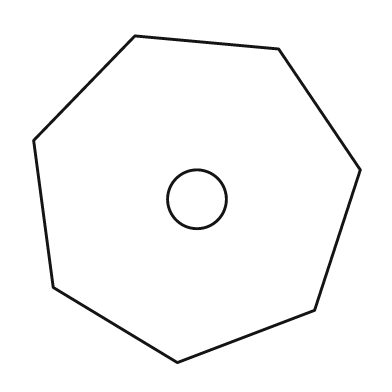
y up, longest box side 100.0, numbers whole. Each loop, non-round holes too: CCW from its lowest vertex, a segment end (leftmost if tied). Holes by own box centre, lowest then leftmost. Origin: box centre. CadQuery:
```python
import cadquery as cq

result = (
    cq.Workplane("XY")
    .moveTo(-6.0, -50.0)
    .lineTo(36.0, -34.0)
    .lineTo(50.0, 9.0)
    .lineTo(25.0, 46.0)
    .lineTo(-19.0, 50.0)
    .lineTo(-50.0, 18.0)
    .lineTo(-44.0, -27.0)
    .close()
    .moveTo(0.0, 0.0)
    .circle(9.0)
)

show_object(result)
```